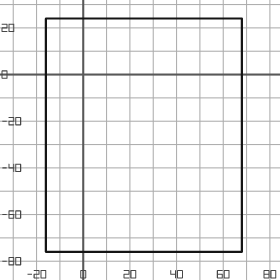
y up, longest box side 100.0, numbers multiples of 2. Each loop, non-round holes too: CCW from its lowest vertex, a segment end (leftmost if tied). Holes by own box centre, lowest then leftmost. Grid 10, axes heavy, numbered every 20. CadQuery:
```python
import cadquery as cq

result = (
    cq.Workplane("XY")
    .moveTo(-16.0, -76.0)
    .lineTo(68.0, -76.0)
    .lineTo(68.0, 24.0)
    .lineTo(-16.0, 24.0)
    .close()
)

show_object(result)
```